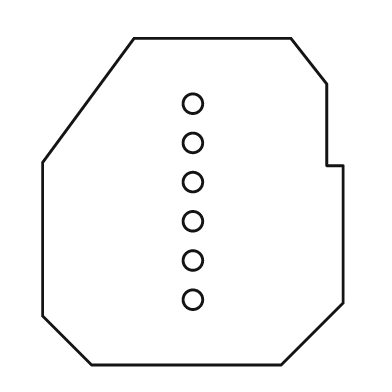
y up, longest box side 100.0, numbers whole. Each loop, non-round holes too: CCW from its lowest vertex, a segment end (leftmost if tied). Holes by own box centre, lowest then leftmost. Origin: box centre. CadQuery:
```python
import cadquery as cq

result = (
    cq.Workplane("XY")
    .moveTo(-31.0, -50.0)
    .lineTo(27.0, -50.0)
    .lineTo(46.0, -31.0)
    .lineTo(46.0, 11.0)
    .lineTo(41.0, 11.0)
    .lineTo(41.0, 36.0)
    .lineTo(30.0, 50.0)
    .lineTo(-18.0, 50.0)
    .lineTo(-46.0, 12.0)
    .lineTo(-46.0, -35.0)
    .close()
    .moveTo(0.0, -30.0)
    .circle(3.0)
    .moveTo(0.0, -18.0)
    .circle(3.0)
    .moveTo(0.0, -6.0)
    .circle(3.0)
    .moveTo(0.0, 6.0)
    .circle(3.0)
    .moveTo(0.0, 18.0)
    .circle(3.0)
    .moveTo(0.0, 30.0)
    .circle(3.0)
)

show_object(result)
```